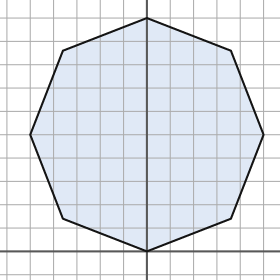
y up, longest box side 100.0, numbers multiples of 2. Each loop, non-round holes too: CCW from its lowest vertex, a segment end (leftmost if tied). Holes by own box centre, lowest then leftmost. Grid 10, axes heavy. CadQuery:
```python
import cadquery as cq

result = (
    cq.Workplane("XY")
    .moveTo(0.0, 0.0)
    .lineTo(36.0, 14.0)
    .lineTo(50.0, 50.0)
    .lineTo(36.0, 86.0)
    .lineTo(0.0, 100.0)
    .lineTo(-36.0, 86.0)
    .lineTo(-50.0, 50.0)
    .lineTo(-36.0, 14.0)
    .close()
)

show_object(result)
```